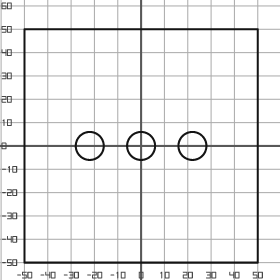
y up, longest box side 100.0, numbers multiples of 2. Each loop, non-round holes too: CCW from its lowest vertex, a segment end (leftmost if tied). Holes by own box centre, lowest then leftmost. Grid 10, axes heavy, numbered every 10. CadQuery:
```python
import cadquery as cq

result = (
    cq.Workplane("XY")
    .moveTo(-50.0, -50.0)
    .lineTo(50.0, -50.0)
    .lineTo(50.0, 50.0)
    .lineTo(-50.0, 50.0)
    .close()
    .moveTo(-22.0, 0.0)
    .circle(6.0)
    .moveTo(0.0, 0.0)
    .circle(6.0)
    .moveTo(22.0, 0.0)
    .circle(6.0)
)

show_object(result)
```